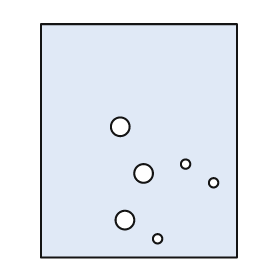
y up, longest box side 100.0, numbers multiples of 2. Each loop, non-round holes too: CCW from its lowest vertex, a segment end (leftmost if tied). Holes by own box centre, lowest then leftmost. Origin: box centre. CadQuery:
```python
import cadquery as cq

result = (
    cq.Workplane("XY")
    .moveTo(-42.0, -50.0)
    .lineTo(42.0, -50.0)
    .lineTo(42.0, 50.0)
    .lineTo(-42.0, 50.0)
    .close()
    .moveTo(8.0, -42.0)
    .circle(2.0)
    .moveTo(-6.0, -34.0)
    .circle(4.0)
    .moveTo(32.0, -18.0)
    .circle(2.0)
    .moveTo(2.0, -14.0)
    .circle(4.0)
    .moveTo(20.0, -10.0)
    .circle(2.0)
    .moveTo(-8.0, 6.0)
    .circle(4.0)
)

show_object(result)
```